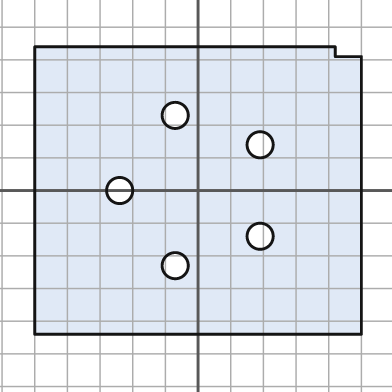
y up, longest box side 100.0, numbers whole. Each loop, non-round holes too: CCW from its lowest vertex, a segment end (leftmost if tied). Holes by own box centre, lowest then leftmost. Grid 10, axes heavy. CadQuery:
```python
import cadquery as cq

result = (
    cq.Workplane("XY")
    .moveTo(-50.0, -44.0)
    .lineTo(50.0, -44.0)
    .lineTo(50.0, 41.0)
    .lineTo(42.0, 41.0)
    .lineTo(42.0, 44.0)
    .lineTo(-50.0, 44.0)
    .close()
    .moveTo(-7.0, -23.0)
    .circle(4.0)
    .moveTo(19.0, -14.0)
    .circle(4.0)
    .moveTo(-24.0, 0.0)
    .circle(4.0)
    .moveTo(19.0, 14.0)
    .circle(4.0)
    .moveTo(-7.0, 23.0)
    .circle(4.0)
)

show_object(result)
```